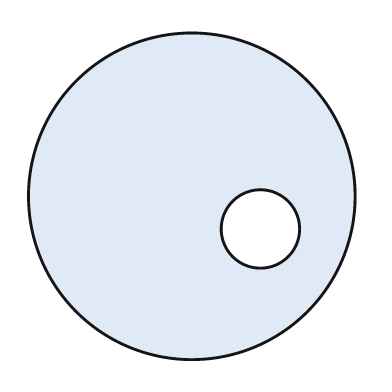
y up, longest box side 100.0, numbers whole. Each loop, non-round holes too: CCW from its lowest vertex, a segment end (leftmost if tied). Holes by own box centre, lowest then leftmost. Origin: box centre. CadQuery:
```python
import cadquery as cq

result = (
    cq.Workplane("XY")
    .moveTo(0.0, 0.0)
    .circle(50.0)
    .moveTo(21.0, -10.0)
    .circle(12.0)
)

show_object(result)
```